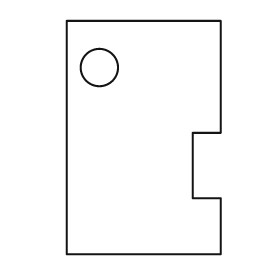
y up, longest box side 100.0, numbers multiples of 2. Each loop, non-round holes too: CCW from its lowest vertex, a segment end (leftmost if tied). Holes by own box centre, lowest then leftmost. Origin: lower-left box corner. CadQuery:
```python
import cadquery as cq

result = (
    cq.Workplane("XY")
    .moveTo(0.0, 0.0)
    .lineTo(66.0, 0.0)
    .lineTo(66.0, 24.0)
    .lineTo(54.0, 24.0)
    .lineTo(54.0, 52.0)
    .lineTo(66.0, 52.0)
    .lineTo(66.0, 100.0)
    .lineTo(0.0, 100.0)
    .close()
    .moveTo(14.0, 80.0)
    .circle(8.0)
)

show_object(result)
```